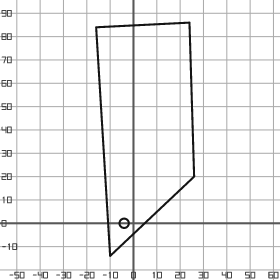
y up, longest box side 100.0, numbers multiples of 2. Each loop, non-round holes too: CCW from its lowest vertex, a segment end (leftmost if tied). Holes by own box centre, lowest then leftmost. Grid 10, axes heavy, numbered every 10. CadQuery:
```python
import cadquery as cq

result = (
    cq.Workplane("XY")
    .moveTo(-10.0, -14.0)
    .lineTo(26.0, 20.0)
    .lineTo(24.0, 86.0)
    .lineTo(-16.0, 84.0)
    .close()
    .moveTo(-4.0, 0.0)
    .circle(2.0)
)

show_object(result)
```